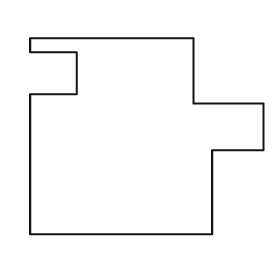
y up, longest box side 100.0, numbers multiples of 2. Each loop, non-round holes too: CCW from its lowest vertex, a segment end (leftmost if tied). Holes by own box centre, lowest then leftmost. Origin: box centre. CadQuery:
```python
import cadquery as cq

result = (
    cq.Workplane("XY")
    .moveTo(-50.0, -42.0)
    .lineTo(28.0, -42.0)
    .lineTo(28.0, -6.0)
    .lineTo(50.0, -6.0)
    .lineTo(50.0, 14.0)
    .lineTo(20.0, 14.0)
    .lineTo(20.0, 42.0)
    .lineTo(-50.0, 42.0)
    .lineTo(-50.0, 36.0)
    .lineTo(-30.0, 36.0)
    .lineTo(-30.0, 18.0)
    .lineTo(-50.0, 18.0)
    .close()
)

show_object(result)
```